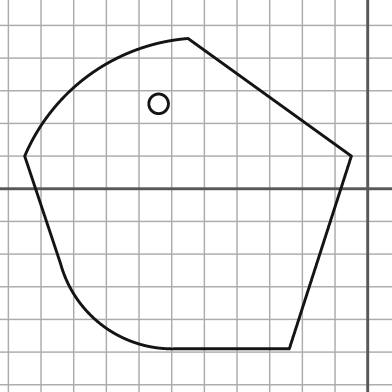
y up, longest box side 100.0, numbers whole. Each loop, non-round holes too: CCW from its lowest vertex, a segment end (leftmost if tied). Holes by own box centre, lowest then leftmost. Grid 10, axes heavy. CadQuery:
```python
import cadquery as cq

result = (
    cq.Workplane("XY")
    .moveTo(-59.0, -49.0)
    .lineTo(-24.0, -49.0)
    .lineTo(-5.0, 10.0)
    .lineTo(-55.0, 46.0)
    .threePointArc((-85.0, 35.0), (-105.0, 10.0))
    .lineTo(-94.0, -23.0)
    .threePointArc((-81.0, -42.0), (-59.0, -49.0))
    .close()
    .moveTo(-64.0, 26.0)
    .circle(3.0)
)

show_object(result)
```